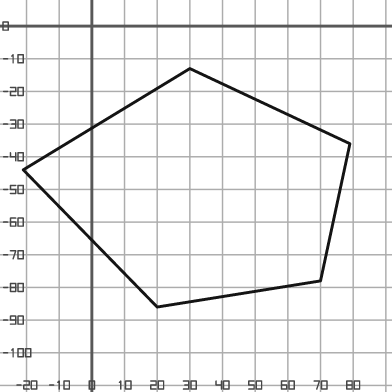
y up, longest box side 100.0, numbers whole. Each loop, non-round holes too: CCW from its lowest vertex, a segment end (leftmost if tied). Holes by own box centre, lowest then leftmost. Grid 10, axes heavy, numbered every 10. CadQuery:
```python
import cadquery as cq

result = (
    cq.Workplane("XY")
    .moveTo(20.0, -86.0)
    .lineTo(70.0, -78.0)
    .lineTo(79.0, -36.0)
    .lineTo(30.0, -13.0)
    .lineTo(-21.0, -44.0)
    .close()
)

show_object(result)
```